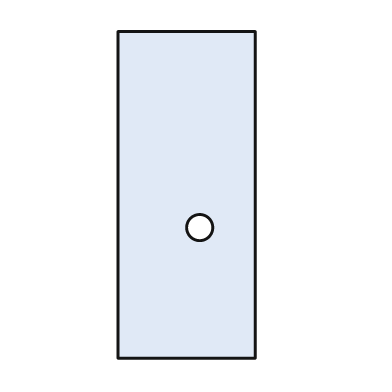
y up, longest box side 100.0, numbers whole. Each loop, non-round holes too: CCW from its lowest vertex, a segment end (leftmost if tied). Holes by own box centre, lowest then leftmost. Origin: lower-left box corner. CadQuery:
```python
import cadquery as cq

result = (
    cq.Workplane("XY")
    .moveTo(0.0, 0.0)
    .lineTo(42.0, 0.0)
    .lineTo(42.0, 100.0)
    .lineTo(0.0, 100.0)
    .close()
    .moveTo(25.0, 40.0)
    .circle(4.0)
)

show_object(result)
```